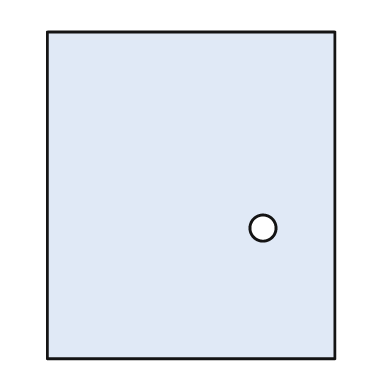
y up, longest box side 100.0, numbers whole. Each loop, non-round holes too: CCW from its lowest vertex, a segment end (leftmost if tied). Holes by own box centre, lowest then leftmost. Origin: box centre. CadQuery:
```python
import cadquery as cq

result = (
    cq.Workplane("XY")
    .moveTo(-44.0, -50.0)
    .lineTo(44.0, -50.0)
    .lineTo(44.0, 50.0)
    .lineTo(-44.0, 50.0)
    .close()
    .moveTo(22.0, -10.0)
    .circle(4.0)
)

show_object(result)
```